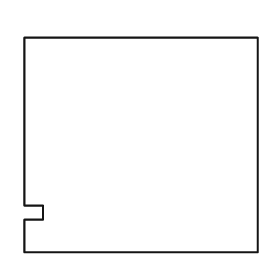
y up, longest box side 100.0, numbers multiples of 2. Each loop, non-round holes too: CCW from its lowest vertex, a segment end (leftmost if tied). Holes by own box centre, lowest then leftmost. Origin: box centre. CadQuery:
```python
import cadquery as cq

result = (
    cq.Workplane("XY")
    .moveTo(-50.0, -46.0)
    .lineTo(50.0, -46.0)
    .lineTo(50.0, 46.0)
    .lineTo(-50.0, 46.0)
    .lineTo(-50.0, -26.0)
    .lineTo(-42.0, -26.0)
    .lineTo(-42.0, -32.0)
    .lineTo(-50.0, -32.0)
    .close()
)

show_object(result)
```